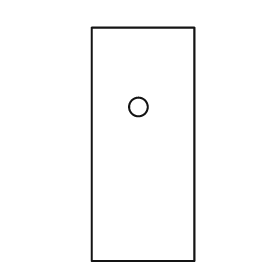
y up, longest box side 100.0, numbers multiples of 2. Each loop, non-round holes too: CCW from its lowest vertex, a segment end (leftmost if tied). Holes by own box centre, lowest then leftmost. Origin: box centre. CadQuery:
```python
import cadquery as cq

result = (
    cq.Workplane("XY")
    .moveTo(-22.0, -50.0)
    .lineTo(22.0, -50.0)
    .lineTo(22.0, 50.0)
    .lineTo(-22.0, 50.0)
    .close()
    .moveTo(-2.0, 16.0)
    .circle(4.0)
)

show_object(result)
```